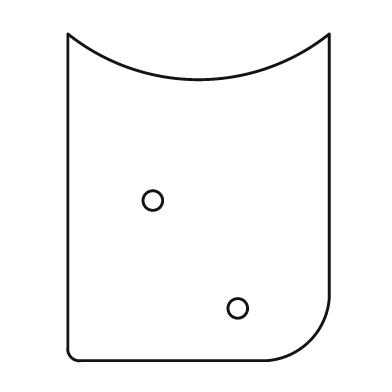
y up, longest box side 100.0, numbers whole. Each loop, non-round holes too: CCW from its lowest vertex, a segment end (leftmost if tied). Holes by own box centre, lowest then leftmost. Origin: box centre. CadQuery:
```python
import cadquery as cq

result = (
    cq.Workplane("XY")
    .moveTo(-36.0, -50.0)
    .lineTo(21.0, -50.0)
    .threePointArc((34.0, -44.0), (40.0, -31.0))
    .lineTo(40.0, 50.0)
    .threePointArc((0.0, 36.0), (-40.0, 50.0))
    .lineTo(-40.0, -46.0)
    .threePointArc((-39.0, -49.0), (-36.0, -50.0))
    .close()
    .moveTo(12.0, -34.0)
    .circle(3.0)
    .moveTo(-14.0, -1.0)
    .circle(3.0)
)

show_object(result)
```